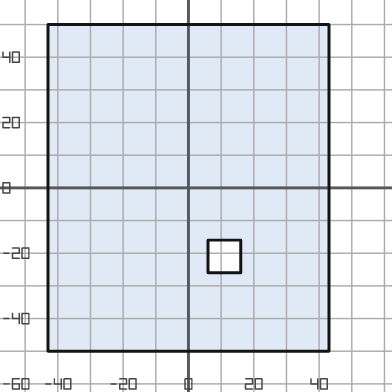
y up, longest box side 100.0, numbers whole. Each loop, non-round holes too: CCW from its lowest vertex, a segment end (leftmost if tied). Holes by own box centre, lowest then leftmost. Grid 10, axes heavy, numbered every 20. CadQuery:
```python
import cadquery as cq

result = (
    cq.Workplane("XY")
    .moveTo(-43.0, -50.0)
    .lineTo(43.0, -50.0)
    .lineTo(43.0, 50.0)
    .lineTo(-43.0, 50.0)
    .close()
    .moveTo(6.0, -26.0)
    .lineTo(16.0, -26.0)
    .lineTo(16.0, -16.0)
    .lineTo(6.0, -16.0)
    .close()
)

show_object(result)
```